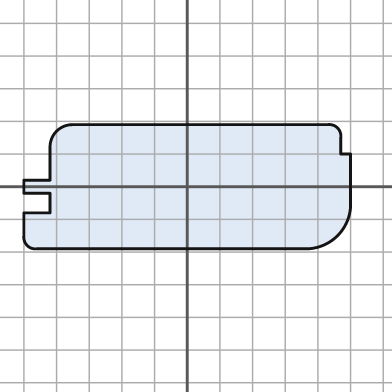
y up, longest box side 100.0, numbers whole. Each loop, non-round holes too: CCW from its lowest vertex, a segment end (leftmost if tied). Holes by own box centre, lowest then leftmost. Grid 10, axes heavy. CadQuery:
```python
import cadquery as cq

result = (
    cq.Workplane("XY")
    .moveTo(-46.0, -19.0)
    .lineTo(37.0, -19.0)
    .threePointArc((46.0, -15.0), (50.0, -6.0))
    .lineTo(50.0, 10.0)
    .lineTo(47.0, 10.0)
    .lineTo(47.0, 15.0)
    .threePointArc((46.0, 18.0), (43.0, 19.0))
    .lineTo(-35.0, 19.0)
    .threePointArc((-40.0, 17.0), (-42.0, 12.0))
    .lineTo(-42.0, 2.0)
    .lineTo(-50.0, 2.0)
    .lineTo(-50.0, -2.0)
    .lineTo(-42.0, -2.0)
    .lineTo(-42.0, -8.0)
    .lineTo(-50.0, -8.0)
    .lineTo(-50.0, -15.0)
    .threePointArc((-49.0, -18.0), (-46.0, -19.0))
    .close()
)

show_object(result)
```